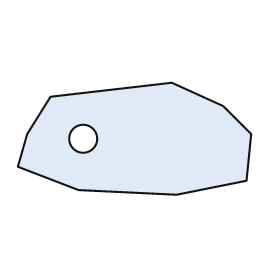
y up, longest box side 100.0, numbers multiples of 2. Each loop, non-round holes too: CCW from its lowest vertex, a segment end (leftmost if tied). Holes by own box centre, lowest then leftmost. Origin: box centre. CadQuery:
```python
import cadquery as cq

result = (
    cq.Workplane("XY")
    .moveTo(18.0, -24.0)
    .lineTo(48.0, -18.0)
    .lineTo(50.0, 2.0)
    .lineTo(38.0, 14.0)
    .lineTo(16.0, 24.0)
    .lineTo(-36.0, 18.0)
    .lineTo(-46.0, 2.0)
    .lineTo(-50.0, -12.0)
    .lineTo(-24.0, -22.0)
    .close()
    .moveTo(-22.0, 0.0)
    .circle(6.0)
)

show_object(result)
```